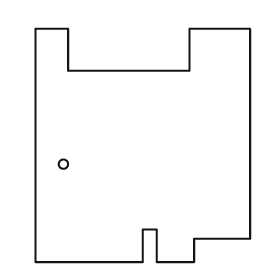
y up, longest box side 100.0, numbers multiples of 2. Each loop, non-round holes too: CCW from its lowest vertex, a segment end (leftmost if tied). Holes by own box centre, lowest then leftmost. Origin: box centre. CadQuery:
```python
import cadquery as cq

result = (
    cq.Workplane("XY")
    .moveTo(-46.0, -50.0)
    .lineTo(0.0, -50.0)
    .lineTo(0.0, -36.0)
    .lineTo(6.0, -36.0)
    .lineTo(6.0, -50.0)
    .lineTo(22.0, -50.0)
    .lineTo(22.0, -40.0)
    .lineTo(46.0, -40.0)
    .lineTo(46.0, 50.0)
    .lineTo(20.0, 50.0)
    .lineTo(20.0, 32.0)
    .lineTo(-32.0, 32.0)
    .lineTo(-32.0, 50.0)
    .lineTo(-46.0, 50.0)
    .close()
    .moveTo(-34.0, -8.0)
    .circle(2.0)
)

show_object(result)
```